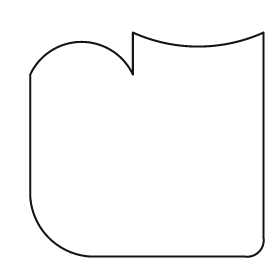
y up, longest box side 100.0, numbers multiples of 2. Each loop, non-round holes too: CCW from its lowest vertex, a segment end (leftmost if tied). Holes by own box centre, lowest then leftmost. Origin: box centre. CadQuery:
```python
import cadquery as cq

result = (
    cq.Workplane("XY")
    .moveTo(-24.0, -48.0)
    .lineTo(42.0, -48.0)
    .threePointArc((48.0, -46.0), (50.0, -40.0))
    .lineTo(50.0, 48.0)
    .threePointArc((22.0, 42.0), (-6.0, 48.0))
    .lineTo(-6.0, 30.0)
    .threePointArc((-28.0, 44.0), (-50.0, 30.0))
    .lineTo(-50.0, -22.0)
    .threePointArc((-42.0, -40.0), (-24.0, -48.0))
    .close()
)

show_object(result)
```